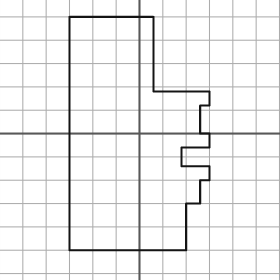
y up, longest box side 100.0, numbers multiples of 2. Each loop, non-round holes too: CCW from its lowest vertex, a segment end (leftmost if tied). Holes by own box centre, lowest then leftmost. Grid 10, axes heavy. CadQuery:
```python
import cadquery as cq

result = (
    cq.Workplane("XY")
    .moveTo(-30.0, -50.0)
    .lineTo(20.0, -50.0)
    .lineTo(20.0, -30.0)
    .lineTo(26.0, -30.0)
    .lineTo(26.0, -20.0)
    .lineTo(30.0, -20.0)
    .lineTo(30.0, -14.0)
    .lineTo(18.0, -14.0)
    .lineTo(18.0, -6.0)
    .lineTo(30.0, -6.0)
    .lineTo(30.0, 0.0)
    .lineTo(26.0, 0.0)
    .lineTo(26.0, 12.0)
    .lineTo(30.0, 12.0)
    .lineTo(30.0, 18.0)
    .lineTo(6.0, 18.0)
    .lineTo(6.0, 50.0)
    .lineTo(-30.0, 50.0)
    .close()
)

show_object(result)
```